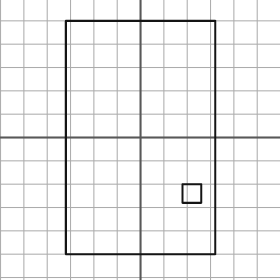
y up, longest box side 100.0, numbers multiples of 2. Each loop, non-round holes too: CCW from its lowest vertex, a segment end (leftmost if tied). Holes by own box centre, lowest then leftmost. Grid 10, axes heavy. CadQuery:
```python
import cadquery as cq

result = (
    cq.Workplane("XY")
    .moveTo(-32.0, -50.0)
    .lineTo(32.0, -50.0)
    .lineTo(32.0, 50.0)
    .lineTo(-32.0, 50.0)
    .close()
    .moveTo(18.0, -28.0)
    .lineTo(26.0, -28.0)
    .lineTo(26.0, -20.0)
    .lineTo(18.0, -20.0)
    .close()
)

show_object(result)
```